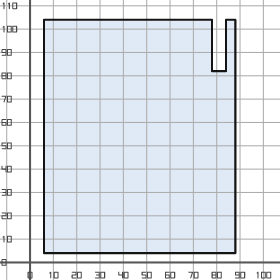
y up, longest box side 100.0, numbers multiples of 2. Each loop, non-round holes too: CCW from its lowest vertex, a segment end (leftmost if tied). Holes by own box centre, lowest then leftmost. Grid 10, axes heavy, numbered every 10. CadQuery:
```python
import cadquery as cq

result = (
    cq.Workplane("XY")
    .moveTo(6.0, 4.0)
    .lineTo(88.0, 4.0)
    .lineTo(88.0, 104.0)
    .lineTo(84.0, 104.0)
    .lineTo(84.0, 82.0)
    .lineTo(78.0, 82.0)
    .lineTo(78.0, 104.0)
    .lineTo(6.0, 104.0)
    .close()
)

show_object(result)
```